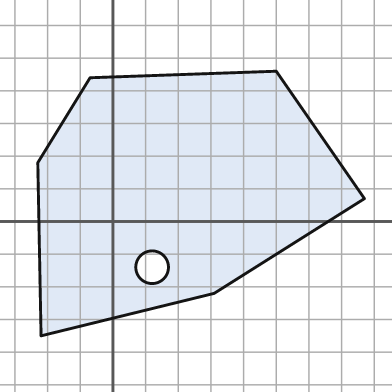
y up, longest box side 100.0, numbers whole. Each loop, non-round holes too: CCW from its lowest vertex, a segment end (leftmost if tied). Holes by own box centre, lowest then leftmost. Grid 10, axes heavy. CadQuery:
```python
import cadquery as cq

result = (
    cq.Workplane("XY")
    .moveTo(-22.0, -35.0)
    .lineTo(31.0, -22.0)
    .lineTo(77.0, 7.0)
    .lineTo(50.0, 46.0)
    .lineTo(-7.0, 44.0)
    .lineTo(-23.0, 18.0)
    .close()
    .moveTo(12.0, -14.0)
    .circle(5.0)
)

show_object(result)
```